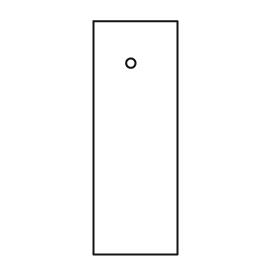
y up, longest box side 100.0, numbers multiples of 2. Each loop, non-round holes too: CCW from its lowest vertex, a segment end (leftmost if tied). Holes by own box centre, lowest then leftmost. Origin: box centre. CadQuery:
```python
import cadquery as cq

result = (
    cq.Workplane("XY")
    .moveTo(-18.0, -50.0)
    .lineTo(18.0, -50.0)
    .lineTo(18.0, 50.0)
    .lineTo(-18.0, 50.0)
    .close()
    .moveTo(-2.0, 32.0)
    .circle(2.0)
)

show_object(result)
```